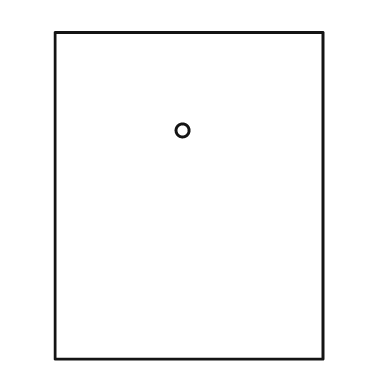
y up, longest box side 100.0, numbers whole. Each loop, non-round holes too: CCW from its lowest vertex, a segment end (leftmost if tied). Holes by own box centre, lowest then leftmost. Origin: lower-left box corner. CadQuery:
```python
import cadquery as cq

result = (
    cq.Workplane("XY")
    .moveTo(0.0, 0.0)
    .lineTo(82.0, 0.0)
    .lineTo(82.0, 100.0)
    .lineTo(0.0, 100.0)
    .close()
    .moveTo(39.0, 70.0)
    .circle(2.0)
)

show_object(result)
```